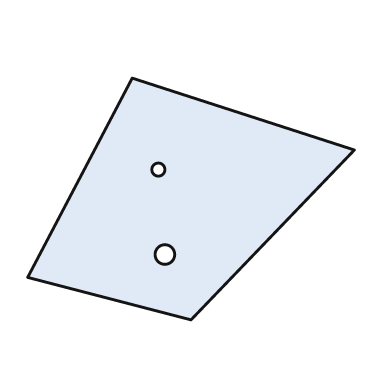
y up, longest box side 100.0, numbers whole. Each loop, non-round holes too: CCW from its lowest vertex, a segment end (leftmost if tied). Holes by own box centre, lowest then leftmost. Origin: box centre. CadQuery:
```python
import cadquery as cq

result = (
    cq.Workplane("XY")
    .moveTo(0.0, -37.0)
    .lineTo(50.0, 15.0)
    .lineTo(-18.0, 37.0)
    .lineTo(-50.0, -24.0)
    .close()
    .moveTo(-8.0, -17.0)
    .circle(3.0)
    .moveTo(-10.0, 9.0)
    .circle(2.0)
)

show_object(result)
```